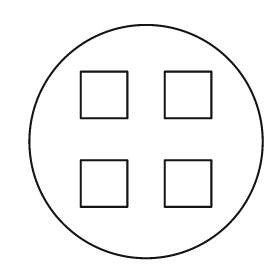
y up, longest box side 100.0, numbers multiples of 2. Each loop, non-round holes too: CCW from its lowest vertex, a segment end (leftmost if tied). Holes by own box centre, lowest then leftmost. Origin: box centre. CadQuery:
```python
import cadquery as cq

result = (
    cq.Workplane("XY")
    .moveTo(0.0, 0.0)
    .circle(50.0)
    .moveTo(-28.0, -28.0)
    .lineTo(-8.0, -28.0)
    .lineTo(-8.0, -8.0)
    .lineTo(-28.0, -8.0)
    .close()
    .moveTo(8.0, -28.0)
    .lineTo(28.0, -28.0)
    .lineTo(28.0, -8.0)
    .lineTo(8.0, -8.0)
    .close()
    .moveTo(-28.0, 10.0)
    .lineTo(-8.0, 10.0)
    .lineTo(-8.0, 30.0)
    .lineTo(-28.0, 30.0)
    .close()
    .moveTo(8.0, 10.0)
    .lineTo(28.0, 10.0)
    .lineTo(28.0, 30.0)
    .lineTo(8.0, 30.0)
    .close()
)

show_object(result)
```